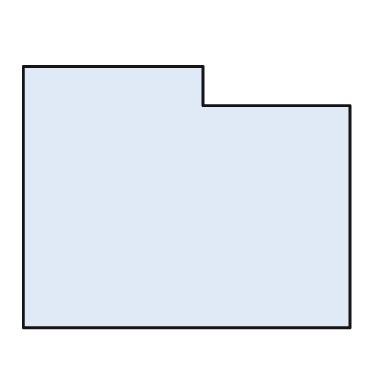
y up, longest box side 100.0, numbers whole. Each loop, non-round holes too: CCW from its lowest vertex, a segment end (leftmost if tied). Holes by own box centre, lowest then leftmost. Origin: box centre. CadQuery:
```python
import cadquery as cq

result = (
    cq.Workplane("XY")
    .moveTo(-50.0, -40.0)
    .lineTo(50.0, -40.0)
    .lineTo(50.0, 28.0)
    .lineTo(5.0, 28.0)
    .lineTo(5.0, 40.0)
    .lineTo(-50.0, 40.0)
    .close()
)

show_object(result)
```